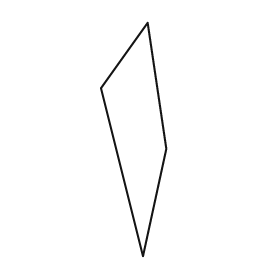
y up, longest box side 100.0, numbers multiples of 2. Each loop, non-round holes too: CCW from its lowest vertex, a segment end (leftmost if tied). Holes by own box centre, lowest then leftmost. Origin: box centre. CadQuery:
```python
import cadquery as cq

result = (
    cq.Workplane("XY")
    .moveTo(4.0, -50.0)
    .lineTo(14.0, -4.0)
    .lineTo(6.0, 50.0)
    .lineTo(-14.0, 22.0)
    .close()
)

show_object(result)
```